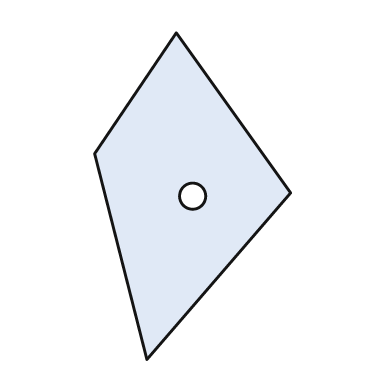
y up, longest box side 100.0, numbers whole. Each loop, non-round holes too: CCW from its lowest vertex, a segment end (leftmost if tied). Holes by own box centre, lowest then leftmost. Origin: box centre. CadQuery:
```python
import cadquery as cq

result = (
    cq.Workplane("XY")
    .moveTo(-14.0, -50.0)
    .lineTo(30.0, 1.0)
    .lineTo(-5.0, 50.0)
    .lineTo(-30.0, 13.0)
    .close()
    .moveTo(0.0, 0.0)
    .circle(4.0)
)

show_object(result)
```